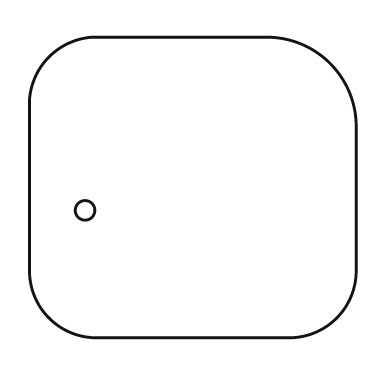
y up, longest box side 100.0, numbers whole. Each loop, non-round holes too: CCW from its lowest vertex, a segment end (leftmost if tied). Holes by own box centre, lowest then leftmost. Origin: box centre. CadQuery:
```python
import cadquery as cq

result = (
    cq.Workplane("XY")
    .moveTo(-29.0, -46.0)
    .lineTo(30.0, -46.0)
    .threePointArc((44.0, -40.0), (50.0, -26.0))
    .lineTo(50.0, 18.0)
    .threePointArc((42.0, 38.0), (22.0, 46.0))
    .lineTo(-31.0, 46.0)
    .threePointArc((-44.0, 40.0), (-50.0, 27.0))
    .lineTo(-50.0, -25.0)
    .threePointArc((-44.0, -40.0), (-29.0, -46.0))
    .close()
    .moveTo(-33.0, -7.0)
    .circle(3.0)
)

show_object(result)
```